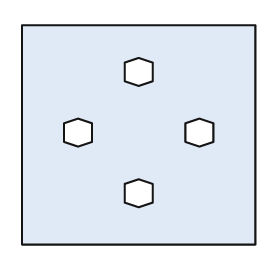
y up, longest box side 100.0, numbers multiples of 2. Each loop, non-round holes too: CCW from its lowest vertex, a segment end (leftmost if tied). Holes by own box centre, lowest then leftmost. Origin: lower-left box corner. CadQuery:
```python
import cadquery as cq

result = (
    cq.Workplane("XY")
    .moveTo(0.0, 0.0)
    .lineTo(100.0, 0.0)
    .lineTo(100.0, 94.0)
    .lineTo(0.0, 94.0)
    .close()
    .moveTo(50.0, 16.0)
    .lineTo(56.0, 18.0)
    .lineTo(56.0, 26.0)
    .lineTo(50.0, 28.0)
    .lineTo(44.0, 26.0)
    .lineTo(44.0, 18.0)
    .close()
    .moveTo(24.0, 42.0)
    .lineTo(30.0, 44.0)
    .lineTo(30.0, 52.0)
    .lineTo(24.0, 54.0)
    .lineTo(18.0, 52.0)
    .lineTo(18.0, 44.0)
    .close()
    .moveTo(76.0, 42.0)
    .lineTo(82.0, 44.0)
    .lineTo(82.0, 52.0)
    .lineTo(76.0, 54.0)
    .lineTo(70.0, 52.0)
    .lineTo(70.0, 44.0)
    .close()
    .moveTo(50.0, 68.0)
    .lineTo(56.0, 70.0)
    .lineTo(56.0, 78.0)
    .lineTo(50.0, 80.0)
    .lineTo(44.0, 78.0)
    .lineTo(44.0, 70.0)
    .close()
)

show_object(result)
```